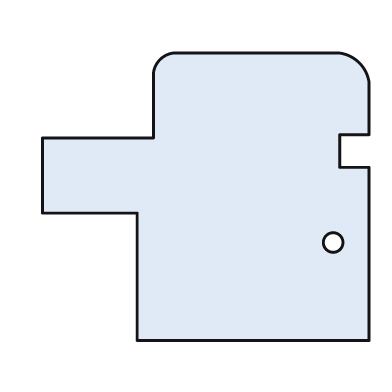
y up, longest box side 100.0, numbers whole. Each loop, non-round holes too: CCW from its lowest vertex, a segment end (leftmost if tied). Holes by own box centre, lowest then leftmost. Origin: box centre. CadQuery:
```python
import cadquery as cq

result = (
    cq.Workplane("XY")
    .moveTo(-21.0, -44.0)
    .lineTo(50.0, -44.0)
    .lineTo(50.0, 9.0)
    .lineTo(41.0, 9.0)
    .lineTo(41.0, 19.0)
    .lineTo(50.0, 19.0)
    .lineTo(50.0, 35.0)
    .threePointArc((47.0, 41.0), (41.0, 44.0))
    .lineTo(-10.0, 44.0)
    .threePointArc((-14.0, 42.0), (-16.0, 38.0))
    .lineTo(-16.0, 18.0)
    .lineTo(-50.0, 18.0)
    .lineTo(-50.0, -5.0)
    .lineTo(-21.0, -5.0)
    .close()
    .moveTo(39.0, -14.0)
    .circle(3.0)
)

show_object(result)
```